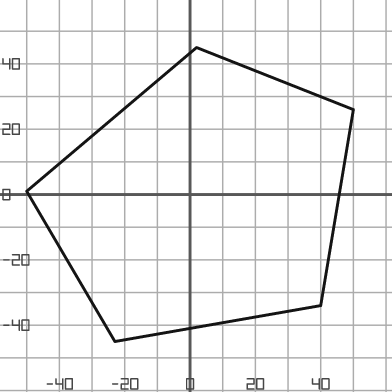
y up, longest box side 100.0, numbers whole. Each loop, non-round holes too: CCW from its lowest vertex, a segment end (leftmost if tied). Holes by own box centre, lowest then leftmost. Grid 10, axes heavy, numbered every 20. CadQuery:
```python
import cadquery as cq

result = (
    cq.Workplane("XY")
    .moveTo(-23.0, -45.0)
    .lineTo(40.0, -34.0)
    .lineTo(50.0, 26.0)
    .lineTo(2.0, 45.0)
    .lineTo(-50.0, 1.0)
    .close()
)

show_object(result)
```